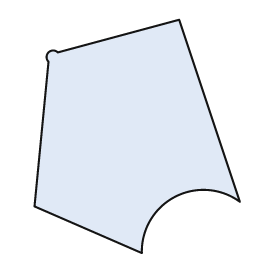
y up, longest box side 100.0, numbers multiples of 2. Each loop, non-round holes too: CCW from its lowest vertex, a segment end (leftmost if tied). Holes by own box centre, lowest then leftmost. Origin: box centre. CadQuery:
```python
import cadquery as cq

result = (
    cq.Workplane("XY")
    .moveTo(2.0, -50.0)
    .threePointArc((16.0, -26.0), (44.0, -28.0))
    .lineTo(18.0, 50.0)
    .lineTo(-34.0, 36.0)
    .threePointArc((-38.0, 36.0), (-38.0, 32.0))
    .lineTo(-44.0, -30.0)
    .close()
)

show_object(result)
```